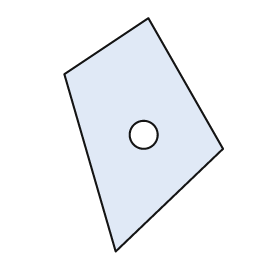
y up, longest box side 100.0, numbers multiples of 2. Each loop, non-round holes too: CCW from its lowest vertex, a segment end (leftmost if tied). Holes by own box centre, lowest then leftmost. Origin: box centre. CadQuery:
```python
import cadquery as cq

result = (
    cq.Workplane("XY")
    .moveTo(-12.0, -50.0)
    .lineTo(34.0, -6.0)
    .lineTo(2.0, 50.0)
    .lineTo(-34.0, 26.0)
    .close()
    .moveTo(0.0, 0.0)
    .circle(6.0)
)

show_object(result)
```